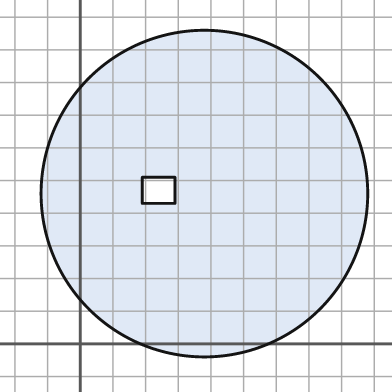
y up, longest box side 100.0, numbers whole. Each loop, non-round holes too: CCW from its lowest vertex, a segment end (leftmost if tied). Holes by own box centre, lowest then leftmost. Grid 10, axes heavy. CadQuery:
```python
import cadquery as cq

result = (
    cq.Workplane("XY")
    .moveTo(38.0, 46.0)
    .circle(50.0)
    .moveTo(19.0, 43.0)
    .lineTo(29.0, 43.0)
    .lineTo(29.0, 51.0)
    .lineTo(19.0, 51.0)
    .close()
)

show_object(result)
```